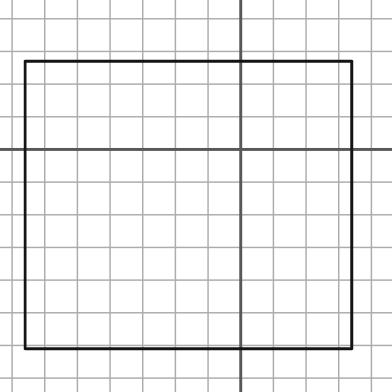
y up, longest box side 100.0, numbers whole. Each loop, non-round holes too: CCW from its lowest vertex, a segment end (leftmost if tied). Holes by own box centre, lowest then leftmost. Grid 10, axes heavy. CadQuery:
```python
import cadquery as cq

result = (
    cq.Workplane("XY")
    .moveTo(-66.0, -61.0)
    .lineTo(34.0, -61.0)
    .lineTo(34.0, 27.0)
    .lineTo(-66.0, 27.0)
    .close()
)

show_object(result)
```